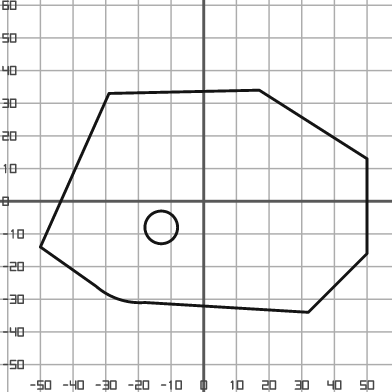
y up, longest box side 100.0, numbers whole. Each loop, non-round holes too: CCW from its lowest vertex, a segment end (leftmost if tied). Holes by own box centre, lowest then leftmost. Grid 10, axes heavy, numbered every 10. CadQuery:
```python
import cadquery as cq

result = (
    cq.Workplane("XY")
    .moveTo(32.0, -34.0)
    .lineTo(50.0, -16.0)
    .lineTo(50.0, 13.0)
    .lineTo(17.0, 34.0)
    .lineTo(-29.0, 33.0)
    .lineTo(-50.0, -14.0)
    .lineTo(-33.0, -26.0)
    .threePointArc((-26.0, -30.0), (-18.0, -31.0))
    .close()
    .moveTo(-13.0, -8.0)
    .circle(5.0)
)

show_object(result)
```